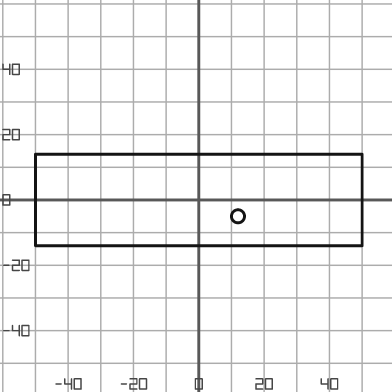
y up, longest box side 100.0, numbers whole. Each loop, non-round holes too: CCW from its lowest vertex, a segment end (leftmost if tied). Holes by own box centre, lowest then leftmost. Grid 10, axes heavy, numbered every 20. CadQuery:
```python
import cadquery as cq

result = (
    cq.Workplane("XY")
    .moveTo(-50.0, -14.0)
    .lineTo(50.0, -14.0)
    .lineTo(50.0, 14.0)
    .lineTo(-50.0, 14.0)
    .close()
    .moveTo(12.0, -5.0)
    .circle(2.0)
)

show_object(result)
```